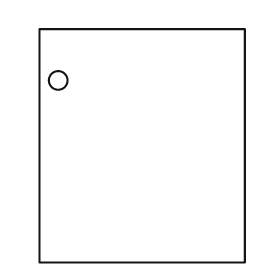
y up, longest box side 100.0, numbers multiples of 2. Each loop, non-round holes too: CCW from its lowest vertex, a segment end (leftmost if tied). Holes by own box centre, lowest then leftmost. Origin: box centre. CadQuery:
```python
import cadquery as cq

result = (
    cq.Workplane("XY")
    .moveTo(-44.0, -50.0)
    .lineTo(44.0, -50.0)
    .lineTo(44.0, 50.0)
    .lineTo(-44.0, 50.0)
    .close()
    .moveTo(-36.0, 28.0)
    .circle(4.0)
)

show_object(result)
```